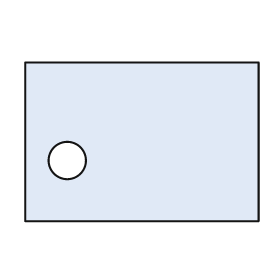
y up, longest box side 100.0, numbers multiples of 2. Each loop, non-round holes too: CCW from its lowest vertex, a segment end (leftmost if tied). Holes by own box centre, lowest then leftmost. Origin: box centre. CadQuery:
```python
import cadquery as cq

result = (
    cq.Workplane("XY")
    .moveTo(-50.0, -34.0)
    .lineTo(50.0, -34.0)
    .lineTo(50.0, 34.0)
    .lineTo(-50.0, 34.0)
    .close()
    .moveTo(-32.0, -8.0)
    .circle(8.0)
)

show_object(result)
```